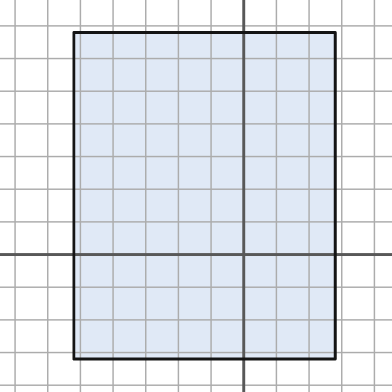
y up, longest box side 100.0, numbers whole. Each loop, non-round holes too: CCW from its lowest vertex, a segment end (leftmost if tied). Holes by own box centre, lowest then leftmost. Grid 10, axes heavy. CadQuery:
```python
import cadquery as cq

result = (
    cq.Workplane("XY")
    .moveTo(-52.0, -32.0)
    .lineTo(28.0, -32.0)
    .lineTo(28.0, 68.0)
    .lineTo(-52.0, 68.0)
    .close()
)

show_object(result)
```